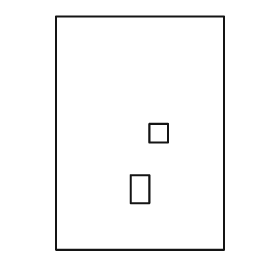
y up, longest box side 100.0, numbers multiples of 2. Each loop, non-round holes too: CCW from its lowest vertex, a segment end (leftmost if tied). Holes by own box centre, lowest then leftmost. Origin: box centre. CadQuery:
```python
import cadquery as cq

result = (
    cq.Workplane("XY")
    .moveTo(-36.0, -50.0)
    .lineTo(36.0, -50.0)
    .lineTo(36.0, 50.0)
    .lineTo(-36.0, 50.0)
    .close()
    .moveTo(-4.0, -30.0)
    .lineTo(4.0, -30.0)
    .lineTo(4.0, -18.0)
    .lineTo(-4.0, -18.0)
    .close()
    .moveTo(4.0, -4.0)
    .lineTo(12.0, -4.0)
    .lineTo(12.0, 4.0)
    .lineTo(4.0, 4.0)
    .close()
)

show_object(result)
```